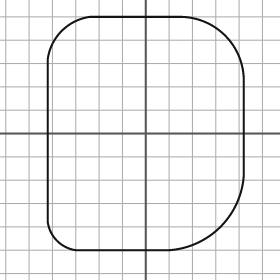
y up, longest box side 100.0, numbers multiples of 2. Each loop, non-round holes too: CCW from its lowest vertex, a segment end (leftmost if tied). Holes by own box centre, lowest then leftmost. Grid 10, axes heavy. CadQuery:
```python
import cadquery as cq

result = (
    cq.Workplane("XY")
    .moveTo(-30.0, -50.0)
    .lineTo(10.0, -50.0)
    .threePointArc((32.0, -40.0), (42.0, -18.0))
    .lineTo(42.0, 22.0)
    .threePointArc((34.0, 42.0), (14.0, 50.0))
    .lineTo(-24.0, 50.0)
    .threePointArc((-36.0, 44.0), (-42.0, 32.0))
    .lineTo(-42.0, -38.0)
    .threePointArc((-38.0, -46.0), (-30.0, -50.0))
    .close()
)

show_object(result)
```